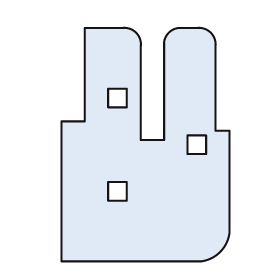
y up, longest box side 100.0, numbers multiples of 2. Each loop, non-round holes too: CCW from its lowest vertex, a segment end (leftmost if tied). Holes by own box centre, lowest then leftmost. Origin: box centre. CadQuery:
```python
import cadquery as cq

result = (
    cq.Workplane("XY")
    .moveTo(-36.0, -50.0)
    .lineTo(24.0, -50.0)
    .threePointArc((32.0, -46.0), (36.0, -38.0))
    .lineTo(36.0, 6.0)
    .lineTo(30.0, 6.0)
    .lineTo(30.0, 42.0)
    .threePointArc((28.0, 48.0), (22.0, 50.0))
    .lineTo(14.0, 50.0)
    .threePointArc((10.0, 48.0), (8.0, 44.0))
    .lineTo(8.0, 2.0)
    .lineTo(-2.0, 2.0)
    .lineTo(-2.0, 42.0)
    .threePointArc((-4.0, 48.0), (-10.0, 50.0))
    .lineTo(-26.0, 50.0)
    .lineTo(-26.0, 10.0)
    .lineTo(-36.0, 10.0)
    .close()
    .moveTo(-16.0, -24.0)
    .lineTo(-8.0, -24.0)
    .lineTo(-8.0, -16.0)
    .lineTo(-16.0, -16.0)
    .close()
    .moveTo(18.0, -4.0)
    .lineTo(26.0, -4.0)
    .lineTo(26.0, 4.0)
    .lineTo(18.0, 4.0)
    .close()
    .moveTo(-16.0, 16.0)
    .lineTo(-8.0, 16.0)
    .lineTo(-8.0, 24.0)
    .lineTo(-16.0, 24.0)
    .close()
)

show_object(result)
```